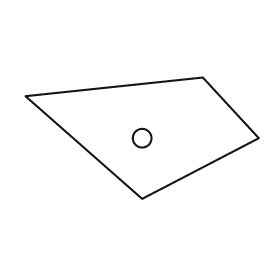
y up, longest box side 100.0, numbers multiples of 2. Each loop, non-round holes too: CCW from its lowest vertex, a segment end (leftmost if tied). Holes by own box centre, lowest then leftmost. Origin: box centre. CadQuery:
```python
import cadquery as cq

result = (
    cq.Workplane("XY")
    .moveTo(0.0, -26.0)
    .lineTo(50.0, 0.0)
    .lineTo(26.0, 26.0)
    .lineTo(-50.0, 18.0)
    .close()
    .moveTo(0.0, 0.0)
    .circle(4.0)
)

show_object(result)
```